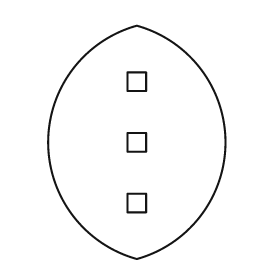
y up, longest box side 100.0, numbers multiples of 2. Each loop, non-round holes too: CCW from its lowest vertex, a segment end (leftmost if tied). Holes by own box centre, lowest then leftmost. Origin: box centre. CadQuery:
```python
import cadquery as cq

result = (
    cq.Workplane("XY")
    .moveTo(0.0, -50.0)
    .threePointArc((38.0, 0.0), (0.0, 50.0))
    .threePointArc((-38.0, 0.0), (0.0, -50.0))
    .close()
    .moveTo(-4.0, -30.0)
    .lineTo(4.0, -30.0)
    .lineTo(4.0, -22.0)
    .lineTo(-4.0, -22.0)
    .close()
    .moveTo(-4.0, -4.0)
    .lineTo(4.0, -4.0)
    .lineTo(4.0, 4.0)
    .lineTo(-4.0, 4.0)
    .close()
    .moveTo(-4.0, 22.0)
    .lineTo(4.0, 22.0)
    .lineTo(4.0, 30.0)
    .lineTo(-4.0, 30.0)
    .close()
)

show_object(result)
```